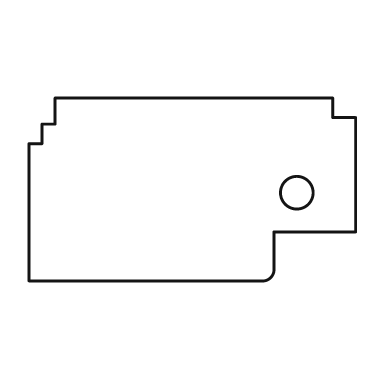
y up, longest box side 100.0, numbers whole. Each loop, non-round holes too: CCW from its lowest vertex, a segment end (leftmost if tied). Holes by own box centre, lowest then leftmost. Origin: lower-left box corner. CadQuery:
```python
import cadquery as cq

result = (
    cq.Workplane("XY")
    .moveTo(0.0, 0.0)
    .lineTo(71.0, 0.0)
    .threePointArc((74.0, 1.0), (75.0, 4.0))
    .lineTo(75.0, 15.0)
    .lineTo(100.0, 15.0)
    .lineTo(100.0, 50.0)
    .lineTo(93.0, 50.0)
    .lineTo(93.0, 56.0)
    .lineTo(8.0, 56.0)
    .lineTo(8.0, 48.0)
    .lineTo(4.0, 48.0)
    .lineTo(4.0, 42.0)
    .lineTo(0.0, 42.0)
    .close()
    .moveTo(82.0, 27.0)
    .circle(5.0)
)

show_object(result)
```